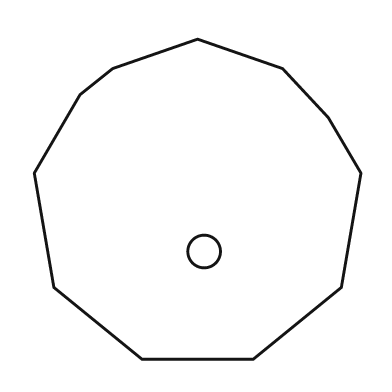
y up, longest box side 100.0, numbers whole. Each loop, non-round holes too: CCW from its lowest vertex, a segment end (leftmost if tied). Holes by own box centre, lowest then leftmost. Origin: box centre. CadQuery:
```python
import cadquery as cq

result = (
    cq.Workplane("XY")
    .moveTo(-17.0, -49.0)
    .lineTo(17.0, -49.0)
    .lineTo(44.0, -27.0)
    .lineTo(50.0, 8.0)
    .lineTo(40.0, 25.0)
    .lineTo(26.0, 40.0)
    .lineTo(0.0, 49.0)
    .lineTo(-26.0, 40.0)
    .lineTo(-36.0, 32.0)
    .lineTo(-50.0, 8.0)
    .lineTo(-44.0, -27.0)
    .close()
    .moveTo(2.0, -16.0)
    .circle(5.0)
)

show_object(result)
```